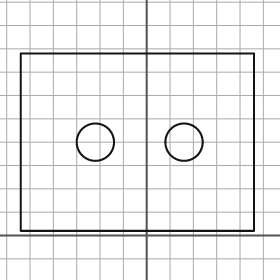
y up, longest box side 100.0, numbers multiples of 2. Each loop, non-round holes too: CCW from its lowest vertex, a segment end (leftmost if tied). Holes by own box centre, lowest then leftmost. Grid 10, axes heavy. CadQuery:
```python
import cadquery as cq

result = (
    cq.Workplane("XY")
    .moveTo(-54.0, 2.0)
    .lineTo(46.0, 2.0)
    .lineTo(46.0, 78.0)
    .lineTo(-54.0, 78.0)
    .close()
    .moveTo(-22.0, 40.0)
    .circle(8.0)
    .moveTo(16.0, 40.0)
    .circle(8.0)
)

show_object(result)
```